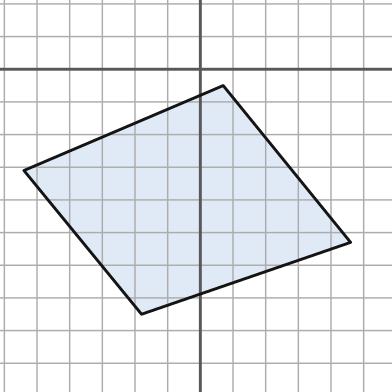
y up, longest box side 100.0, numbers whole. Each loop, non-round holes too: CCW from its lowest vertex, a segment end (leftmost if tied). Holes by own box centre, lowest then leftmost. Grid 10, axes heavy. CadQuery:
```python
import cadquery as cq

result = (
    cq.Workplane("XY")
    .moveTo(-18.0, -75.0)
    .lineTo(46.0, -53.0)
    .lineTo(7.0, -5.0)
    .lineTo(-54.0, -31.0)
    .close()
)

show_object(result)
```